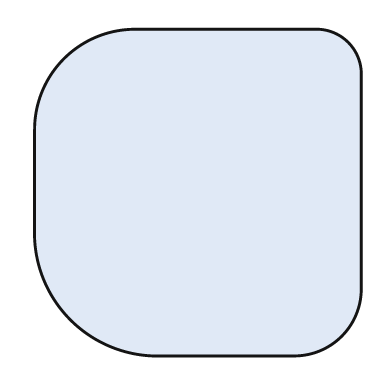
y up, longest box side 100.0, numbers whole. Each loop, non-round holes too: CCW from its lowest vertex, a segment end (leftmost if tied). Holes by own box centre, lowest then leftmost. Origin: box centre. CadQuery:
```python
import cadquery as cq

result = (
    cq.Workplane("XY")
    .moveTo(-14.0, -50.0)
    .lineTo(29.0, -50.0)
    .threePointArc((44.0, -44.0), (50.0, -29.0))
    .lineTo(50.0, 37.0)
    .threePointArc((46.0, 46.0), (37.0, 50.0))
    .lineTo(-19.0, 50.0)
    .threePointArc((-41.0, 41.0), (-50.0, 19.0))
    .lineTo(-50.0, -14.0)
    .threePointArc((-39.0, -39.0), (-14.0, -50.0))
    .close()
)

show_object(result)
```